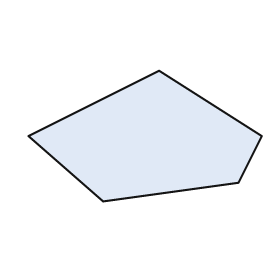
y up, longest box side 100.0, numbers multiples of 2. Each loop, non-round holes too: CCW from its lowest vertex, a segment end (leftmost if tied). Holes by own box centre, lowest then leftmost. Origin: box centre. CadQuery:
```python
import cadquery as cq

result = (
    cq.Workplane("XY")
    .moveTo(-18.0, -28.0)
    .lineTo(40.0, -20.0)
    .lineTo(50.0, 0.0)
    .lineTo(6.0, 28.0)
    .lineTo(-50.0, 0.0)
    .close()
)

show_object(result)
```